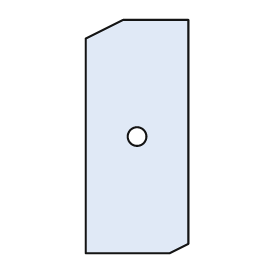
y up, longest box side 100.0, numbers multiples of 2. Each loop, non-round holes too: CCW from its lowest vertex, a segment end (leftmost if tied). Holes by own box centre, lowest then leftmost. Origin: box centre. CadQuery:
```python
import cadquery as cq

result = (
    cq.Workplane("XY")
    .moveTo(-22.0, -50.0)
    .lineTo(14.0, -50.0)
    .lineTo(22.0, -46.0)
    .lineTo(22.0, 50.0)
    .lineTo(-6.0, 50.0)
    .lineTo(-22.0, 42.0)
    .close()
    .moveTo(0.0, 0.0)
    .circle(4.0)
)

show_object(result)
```